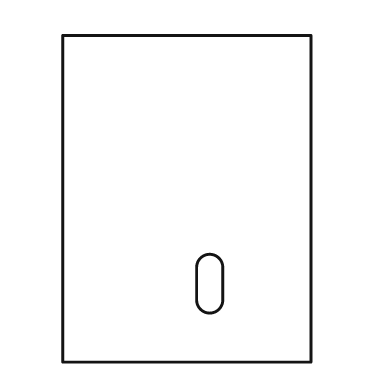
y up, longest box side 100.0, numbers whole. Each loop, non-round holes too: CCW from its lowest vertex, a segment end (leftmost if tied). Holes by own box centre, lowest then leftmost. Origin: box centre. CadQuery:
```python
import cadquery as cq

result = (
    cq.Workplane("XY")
    .moveTo(-38.0, -50.0)
    .lineTo(38.0, -50.0)
    .lineTo(38.0, 50.0)
    .lineTo(-38.0, 50.0)
    .close()
    .moveTo(3.0, -31.0)
    .threePointArc((7.0, -35.0), (11.0, -31.0))
    .lineTo(11.0, -21.0)
    .threePointArc((7.0, -17.0), (3.0, -21.0))
    .close()
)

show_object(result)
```